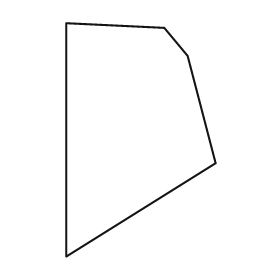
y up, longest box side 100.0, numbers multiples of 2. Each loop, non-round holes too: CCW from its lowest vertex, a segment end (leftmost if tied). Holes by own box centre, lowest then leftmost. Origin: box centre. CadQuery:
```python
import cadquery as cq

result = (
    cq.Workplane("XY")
    .moveTo(-32.0, -50.0)
    .lineTo(32.0, -10.0)
    .lineTo(20.0, 36.0)
    .lineTo(10.0, 48.0)
    .lineTo(-32.0, 50.0)
    .close()
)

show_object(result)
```